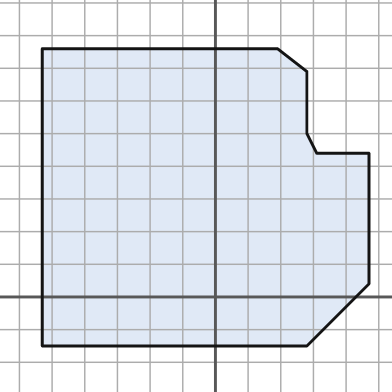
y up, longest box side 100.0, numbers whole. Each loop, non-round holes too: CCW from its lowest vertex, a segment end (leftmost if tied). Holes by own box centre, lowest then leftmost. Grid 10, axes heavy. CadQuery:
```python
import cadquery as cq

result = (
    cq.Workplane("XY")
    .moveTo(-53.0, -15.0)
    .lineTo(28.0, -15.0)
    .lineTo(47.0, 4.0)
    .lineTo(47.0, 44.0)
    .lineTo(31.0, 44.0)
    .lineTo(28.0, 50.0)
    .lineTo(28.0, 69.0)
    .lineTo(19.0, 76.0)
    .lineTo(-53.0, 76.0)
    .close()
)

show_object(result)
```